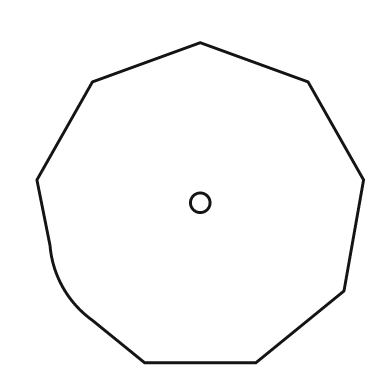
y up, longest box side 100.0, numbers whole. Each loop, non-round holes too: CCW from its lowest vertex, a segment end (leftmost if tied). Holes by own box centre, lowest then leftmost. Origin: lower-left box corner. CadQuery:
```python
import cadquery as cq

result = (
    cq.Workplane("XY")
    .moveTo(33.0, 0.0)
    .lineTo(67.0, 0.0)
    .lineTo(94.0, 22.0)
    .lineTo(100.0, 56.0)
    .lineTo(83.0, 86.0)
    .lineTo(50.0, 98.0)
    .lineTo(17.0, 86.0)
    .lineTo(0.0, 56.0)
    .lineTo(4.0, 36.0)
    .threePointArc((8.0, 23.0), (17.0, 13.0))
    .close()
    .moveTo(50.0, 49.0)
    .circle(3.0)
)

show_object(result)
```